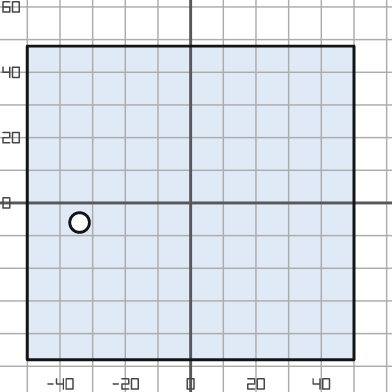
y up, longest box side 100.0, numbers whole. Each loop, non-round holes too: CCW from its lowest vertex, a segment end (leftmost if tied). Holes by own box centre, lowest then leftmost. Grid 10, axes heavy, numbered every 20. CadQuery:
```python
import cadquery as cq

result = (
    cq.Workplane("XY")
    .moveTo(-50.0, -48.0)
    .lineTo(50.0, -48.0)
    .lineTo(50.0, 48.0)
    .lineTo(-50.0, 48.0)
    .close()
    .moveTo(-34.0, -6.0)
    .circle(3.0)
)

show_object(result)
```